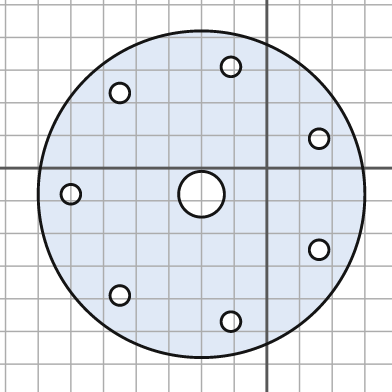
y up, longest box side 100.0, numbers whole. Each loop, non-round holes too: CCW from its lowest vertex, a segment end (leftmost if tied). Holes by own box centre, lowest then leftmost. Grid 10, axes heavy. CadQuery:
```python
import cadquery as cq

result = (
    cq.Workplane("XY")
    .moveTo(-20.0, -8.0)
    .circle(50.0)
    .moveTo(-11.0, -47.0)
    .circle(3.0)
    .moveTo(-45.0, -39.0)
    .circle(3.0)
    .moveTo(16.0, -25.0)
    .circle(3.0)
    .moveTo(-60.0, -8.0)
    .circle(3.0)
    .moveTo(-20.0, -8.0)
    .circle(7.0)
    .moveTo(16.0, 9.0)
    .circle(3.0)
    .moveTo(-45.0, 23.0)
    .circle(3.0)
    .moveTo(-11.0, 31.0)
    .circle(3.0)
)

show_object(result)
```